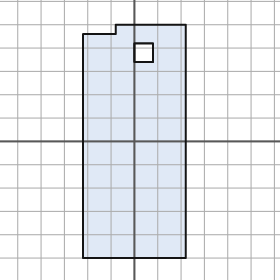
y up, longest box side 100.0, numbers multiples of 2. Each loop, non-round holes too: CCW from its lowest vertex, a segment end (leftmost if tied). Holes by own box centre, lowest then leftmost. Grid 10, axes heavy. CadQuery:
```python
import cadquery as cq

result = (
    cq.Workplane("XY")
    .moveTo(-22.0, -50.0)
    .lineTo(22.0, -50.0)
    .lineTo(22.0, 50.0)
    .lineTo(-8.0, 50.0)
    .lineTo(-8.0, 46.0)
    .lineTo(-22.0, 46.0)
    .close()
    .moveTo(0.0, 34.0)
    .lineTo(8.0, 34.0)
    .lineTo(8.0, 42.0)
    .lineTo(0.0, 42.0)
    .close()
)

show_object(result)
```